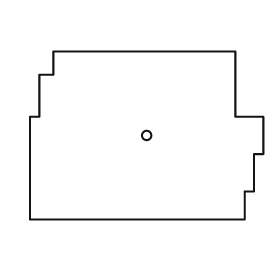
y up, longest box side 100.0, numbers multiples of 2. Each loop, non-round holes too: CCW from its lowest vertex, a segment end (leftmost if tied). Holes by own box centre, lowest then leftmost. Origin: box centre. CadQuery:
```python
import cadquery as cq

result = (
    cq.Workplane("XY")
    .moveTo(-50.0, -36.0)
    .lineTo(42.0, -36.0)
    .lineTo(42.0, -24.0)
    .lineTo(46.0, -24.0)
    .lineTo(46.0, -8.0)
    .lineTo(50.0, -8.0)
    .lineTo(50.0, 8.0)
    .lineTo(38.0, 8.0)
    .lineTo(38.0, 36.0)
    .lineTo(-40.0, 36.0)
    .lineTo(-40.0, 26.0)
    .lineTo(-46.0, 26.0)
    .lineTo(-46.0, 8.0)
    .lineTo(-50.0, 8.0)
    .close()
    .moveTo(0.0, 0.0)
    .circle(2.0)
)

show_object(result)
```